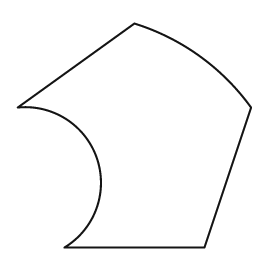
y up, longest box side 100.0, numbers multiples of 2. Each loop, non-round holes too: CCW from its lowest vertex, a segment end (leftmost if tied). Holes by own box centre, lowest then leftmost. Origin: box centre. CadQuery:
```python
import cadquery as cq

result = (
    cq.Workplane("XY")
    .moveTo(-30.0, -48.0)
    .lineTo(30.0, -48.0)
    .lineTo(50.0, 12.0)
    .threePointArc((28.0, 34.0), (0.0, 48.0))
    .lineTo(-50.0, 12.0)
    .threePointArc((-16.0, -10.0), (-30.0, -48.0))
    .close()
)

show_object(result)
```